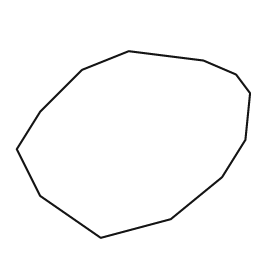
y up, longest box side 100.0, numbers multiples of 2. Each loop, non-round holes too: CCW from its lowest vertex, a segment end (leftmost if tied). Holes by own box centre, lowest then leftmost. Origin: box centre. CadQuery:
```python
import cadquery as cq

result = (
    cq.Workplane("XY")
    .moveTo(-14.0, -40.0)
    .lineTo(16.0, -32.0)
    .lineTo(38.0, -14.0)
    .lineTo(48.0, 2.0)
    .lineTo(50.0, 22.0)
    .lineTo(44.0, 30.0)
    .lineTo(30.0, 36.0)
    .lineTo(-2.0, 40.0)
    .lineTo(-22.0, 32.0)
    .lineTo(-40.0, 14.0)
    .lineTo(-50.0, -2.0)
    .lineTo(-40.0, -22.0)
    .close()
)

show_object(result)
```